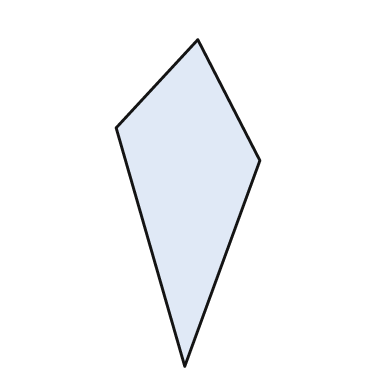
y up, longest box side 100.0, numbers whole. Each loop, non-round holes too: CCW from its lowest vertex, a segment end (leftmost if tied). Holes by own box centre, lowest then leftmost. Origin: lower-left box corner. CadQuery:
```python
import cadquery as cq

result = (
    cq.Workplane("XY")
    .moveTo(21.0, 0.0)
    .lineTo(44.0, 63.0)
    .lineTo(25.0, 100.0)
    .lineTo(0.0, 73.0)
    .close()
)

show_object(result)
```